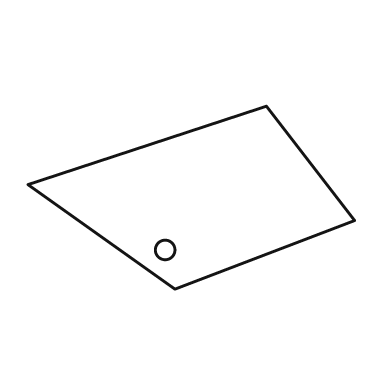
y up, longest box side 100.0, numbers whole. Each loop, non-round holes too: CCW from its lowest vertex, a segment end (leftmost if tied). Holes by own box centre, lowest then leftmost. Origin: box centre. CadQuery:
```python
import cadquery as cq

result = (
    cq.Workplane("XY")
    .moveTo(-5.0, -28.0)
    .lineTo(50.0, -7.0)
    .lineTo(23.0, 28.0)
    .lineTo(-50.0, 4.0)
    .close()
    .moveTo(-8.0, -16.0)
    .circle(3.0)
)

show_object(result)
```